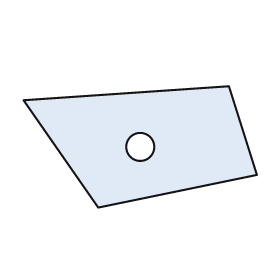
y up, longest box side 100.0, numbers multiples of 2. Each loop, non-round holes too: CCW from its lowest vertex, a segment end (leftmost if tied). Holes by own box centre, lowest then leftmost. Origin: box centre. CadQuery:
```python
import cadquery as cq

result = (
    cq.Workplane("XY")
    .moveTo(-18.0, -26.0)
    .lineTo(50.0, -12.0)
    .lineTo(38.0, 26.0)
    .lineTo(-50.0, 20.0)
    .close()
    .moveTo(0.0, 0.0)
    .circle(6.0)
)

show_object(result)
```